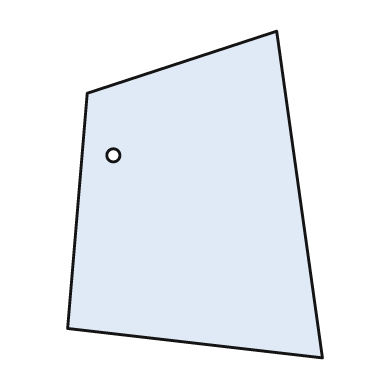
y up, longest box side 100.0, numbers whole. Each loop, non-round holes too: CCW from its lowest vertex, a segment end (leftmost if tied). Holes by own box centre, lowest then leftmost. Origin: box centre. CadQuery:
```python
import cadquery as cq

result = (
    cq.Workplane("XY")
    .moveTo(39.0, -50.0)
    .lineTo(25.0, 50.0)
    .lineTo(-33.0, 31.0)
    .lineTo(-39.0, -41.0)
    .close()
    .moveTo(-25.0, 12.0)
    .circle(2.0)
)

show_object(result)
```